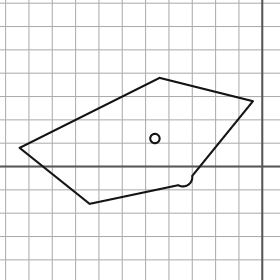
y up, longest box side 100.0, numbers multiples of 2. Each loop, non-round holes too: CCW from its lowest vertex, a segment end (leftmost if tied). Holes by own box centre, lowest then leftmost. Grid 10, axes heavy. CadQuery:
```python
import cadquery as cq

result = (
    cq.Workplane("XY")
    .moveTo(-74.0, -16.0)
    .lineTo(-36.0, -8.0)
    .threePointArc((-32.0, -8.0), (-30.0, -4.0))
    .lineTo(-4.0, 28.0)
    .lineTo(-44.0, 38.0)
    .lineTo(-104.0, 8.0)
    .close()
    .moveTo(-46.0, 12.0)
    .circle(2.0)
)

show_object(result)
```